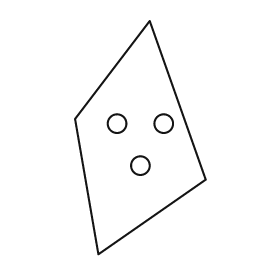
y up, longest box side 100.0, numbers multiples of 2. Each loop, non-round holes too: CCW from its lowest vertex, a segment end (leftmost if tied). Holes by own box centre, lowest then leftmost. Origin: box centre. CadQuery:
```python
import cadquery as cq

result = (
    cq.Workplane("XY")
    .moveTo(-18.0, -50.0)
    .lineTo(28.0, -18.0)
    .lineTo(4.0, 50.0)
    .lineTo(-28.0, 8.0)
    .close()
    .moveTo(0.0, -12.0)
    .circle(4.0)
    .moveTo(-10.0, 6.0)
    .circle(4.0)
    .moveTo(10.0, 6.0)
    .circle(4.0)
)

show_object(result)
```